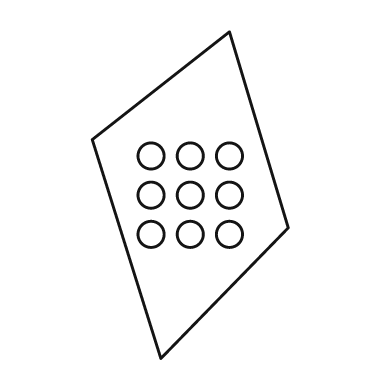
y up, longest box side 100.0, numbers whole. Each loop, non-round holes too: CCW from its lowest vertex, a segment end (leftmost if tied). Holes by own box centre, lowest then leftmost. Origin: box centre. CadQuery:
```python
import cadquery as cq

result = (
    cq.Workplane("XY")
    .moveTo(-9.0, -50.0)
    .lineTo(30.0, -10.0)
    .lineTo(12.0, 50.0)
    .lineTo(-30.0, 17.0)
    .close()
    .moveTo(-12.0, -12.0)
    .circle(4.0)
    .moveTo(0.0, -12.0)
    .circle(4.0)
    .moveTo(12.0, -12.0)
    .circle(4.0)
    .moveTo(-12.0, 0.0)
    .circle(4.0)
    .moveTo(0.0, 0.0)
    .circle(4.0)
    .moveTo(12.0, 0.0)
    .circle(4.0)
    .moveTo(-12.0, 12.0)
    .circle(4.0)
    .moveTo(0.0, 12.0)
    .circle(4.0)
    .moveTo(12.0, 12.0)
    .circle(4.0)
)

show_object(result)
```